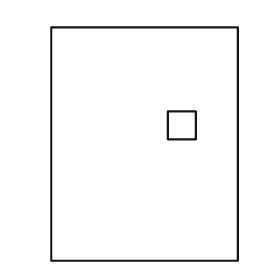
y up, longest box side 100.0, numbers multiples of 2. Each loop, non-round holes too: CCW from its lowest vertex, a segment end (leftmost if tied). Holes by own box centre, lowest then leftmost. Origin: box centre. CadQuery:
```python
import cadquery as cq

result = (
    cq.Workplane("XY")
    .moveTo(-40.0, -50.0)
    .lineTo(40.0, -50.0)
    .lineTo(40.0, 50.0)
    .lineTo(-40.0, 50.0)
    .close()
    .moveTo(10.0, 2.0)
    .lineTo(22.0, 2.0)
    .lineTo(22.0, 14.0)
    .lineTo(10.0, 14.0)
    .close()
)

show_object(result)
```